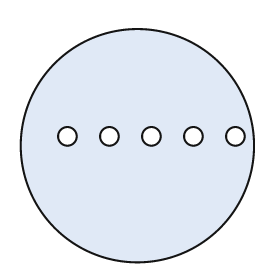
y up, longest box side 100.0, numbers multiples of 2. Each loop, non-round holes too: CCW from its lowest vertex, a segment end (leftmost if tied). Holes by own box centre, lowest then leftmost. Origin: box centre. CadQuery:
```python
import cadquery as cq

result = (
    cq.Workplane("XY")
    .moveTo(0.0, 0.0)
    .circle(50.0)
    .moveTo(-30.0, 4.0)
    .circle(4.0)
    .moveTo(-12.0, 4.0)
    .circle(4.0)
    .moveTo(6.0, 4.0)
    .circle(4.0)
    .moveTo(24.0, 4.0)
    .circle(4.0)
    .moveTo(42.0, 4.0)
    .circle(4.0)
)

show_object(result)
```